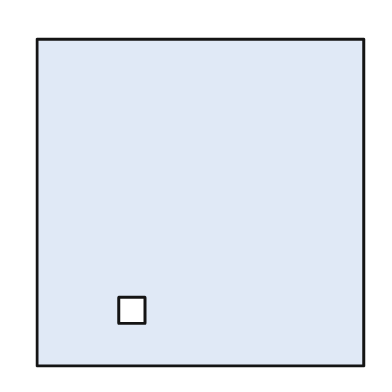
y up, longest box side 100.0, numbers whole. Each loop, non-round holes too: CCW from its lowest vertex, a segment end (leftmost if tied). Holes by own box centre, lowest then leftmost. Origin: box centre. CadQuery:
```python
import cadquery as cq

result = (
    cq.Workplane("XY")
    .moveTo(-50.0, -50.0)
    .lineTo(50.0, -50.0)
    .lineTo(50.0, 50.0)
    .lineTo(-50.0, 50.0)
    .close()
    .moveTo(-25.0, -37.0)
    .lineTo(-17.0, -37.0)
    .lineTo(-17.0, -29.0)
    .lineTo(-25.0, -29.0)
    .close()
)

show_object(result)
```